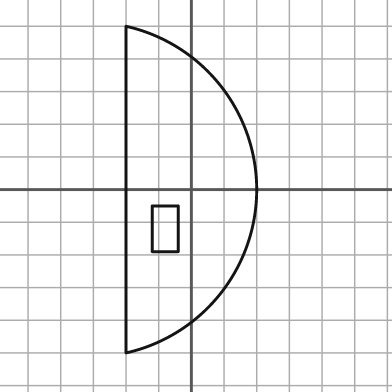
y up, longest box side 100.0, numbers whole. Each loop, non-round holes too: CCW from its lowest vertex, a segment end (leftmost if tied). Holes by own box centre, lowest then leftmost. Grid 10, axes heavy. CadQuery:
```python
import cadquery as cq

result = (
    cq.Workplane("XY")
    .moveTo(-20.0, -50.0)
    .threePointArc((20.0, 0.0), (-20.0, 50.0))
    .close()
    .moveTo(-12.0, -19.0)
    .lineTo(-4.0, -19.0)
    .lineTo(-4.0, -5.0)
    .lineTo(-12.0, -5.0)
    .close()
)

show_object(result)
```